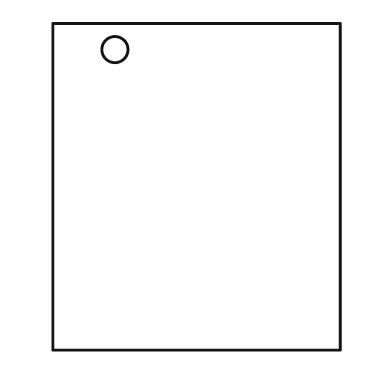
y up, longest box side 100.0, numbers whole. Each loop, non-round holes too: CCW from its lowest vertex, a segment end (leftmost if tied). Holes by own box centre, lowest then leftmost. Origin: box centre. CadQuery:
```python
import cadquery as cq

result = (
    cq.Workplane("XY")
    .moveTo(-44.0, -50.0)
    .lineTo(44.0, -50.0)
    .lineTo(44.0, 50.0)
    .lineTo(-44.0, 50.0)
    .close()
    .moveTo(-25.0, 42.0)
    .circle(4.0)
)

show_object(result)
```